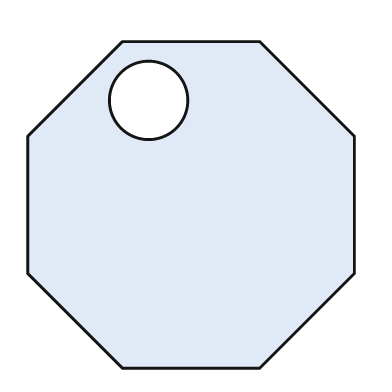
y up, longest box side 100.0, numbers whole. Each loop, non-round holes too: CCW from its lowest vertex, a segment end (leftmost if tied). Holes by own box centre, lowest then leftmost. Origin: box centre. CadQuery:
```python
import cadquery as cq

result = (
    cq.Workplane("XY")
    .moveTo(-21.0, -50.0)
    .lineTo(21.0, -50.0)
    .lineTo(50.0, -21.0)
    .lineTo(50.0, 21.0)
    .lineTo(21.0, 50.0)
    .lineTo(-21.0, 50.0)
    .lineTo(-50.0, 21.0)
    .lineTo(-50.0, -21.0)
    .close()
    .moveTo(-13.0, 32.0)
    .circle(12.0)
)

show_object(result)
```